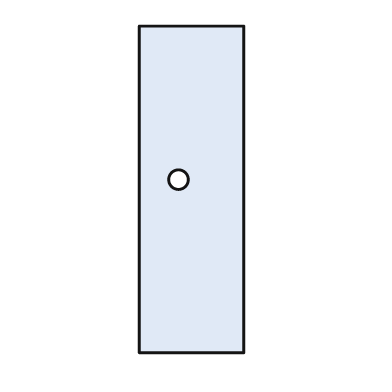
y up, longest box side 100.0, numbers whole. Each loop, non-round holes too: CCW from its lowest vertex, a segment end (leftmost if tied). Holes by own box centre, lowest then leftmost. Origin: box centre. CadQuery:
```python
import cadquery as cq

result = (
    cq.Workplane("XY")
    .moveTo(-16.0, -50.0)
    .lineTo(16.0, -50.0)
    .lineTo(16.0, 50.0)
    .lineTo(-16.0, 50.0)
    .close()
    .moveTo(-4.0, 3.0)
    .circle(3.0)
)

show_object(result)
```